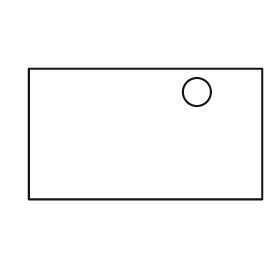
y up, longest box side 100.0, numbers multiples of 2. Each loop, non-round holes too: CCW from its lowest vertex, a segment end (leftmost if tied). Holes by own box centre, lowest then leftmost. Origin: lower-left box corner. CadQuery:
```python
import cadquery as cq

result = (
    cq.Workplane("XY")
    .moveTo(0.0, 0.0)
    .lineTo(100.0, 0.0)
    .lineTo(100.0, 56.0)
    .lineTo(0.0, 56.0)
    .close()
    .moveTo(72.0, 46.0)
    .circle(6.0)
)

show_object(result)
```